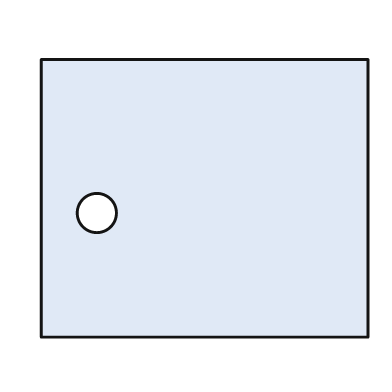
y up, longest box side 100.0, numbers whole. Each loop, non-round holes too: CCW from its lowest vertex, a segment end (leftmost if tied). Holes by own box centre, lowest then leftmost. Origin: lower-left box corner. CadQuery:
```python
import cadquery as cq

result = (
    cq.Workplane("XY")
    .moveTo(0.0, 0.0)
    .lineTo(100.0, 0.0)
    .lineTo(100.0, 85.0)
    .lineTo(0.0, 85.0)
    .close()
    .moveTo(17.0, 38.0)
    .circle(6.0)
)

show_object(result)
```